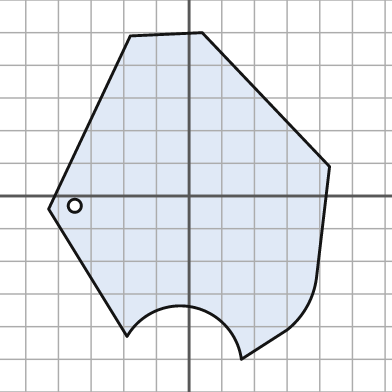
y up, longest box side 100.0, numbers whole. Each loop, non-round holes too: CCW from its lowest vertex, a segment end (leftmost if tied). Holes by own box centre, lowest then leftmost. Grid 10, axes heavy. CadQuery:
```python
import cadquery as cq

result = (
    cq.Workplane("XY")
    .moveTo(16.0, -50.0)
    .lineTo(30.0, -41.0)
    .threePointArc((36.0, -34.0), (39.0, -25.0))
    .lineTo(43.0, 9.0)
    .lineTo(4.0, 50.0)
    .lineTo(-18.0, 49.0)
    .lineTo(-43.0, -4.0)
    .lineTo(-19.0, -43.0)
    .threePointArc((1.0, -34.0), (16.0, -50.0))
    .close()
    .moveTo(-35.0, -3.0)
    .circle(2.0)
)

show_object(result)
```